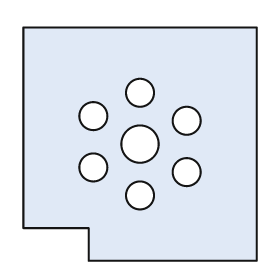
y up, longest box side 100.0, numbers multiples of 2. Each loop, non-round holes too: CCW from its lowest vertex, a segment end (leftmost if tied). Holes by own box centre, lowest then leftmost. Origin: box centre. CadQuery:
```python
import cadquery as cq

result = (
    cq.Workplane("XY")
    .moveTo(-22.0, -50.0)
    .lineTo(50.0, -50.0)
    .lineTo(50.0, 50.0)
    .lineTo(-50.0, 50.0)
    .lineTo(-50.0, -36.0)
    .lineTo(-22.0, -36.0)
    .close()
    .moveTo(0.0, -22.0)
    .circle(6.0)
    .moveTo(20.0, -12.0)
    .circle(6.0)
    .moveTo(-20.0, -10.0)
    .circle(6.0)
    .moveTo(0.0, 0.0)
    .circle(8.0)
    .moveTo(20.0, 10.0)
    .circle(6.0)
    .moveTo(-20.0, 12.0)
    .circle(6.0)
    .moveTo(0.0, 22.0)
    .circle(6.0)
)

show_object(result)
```